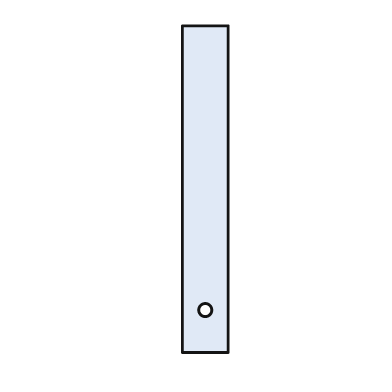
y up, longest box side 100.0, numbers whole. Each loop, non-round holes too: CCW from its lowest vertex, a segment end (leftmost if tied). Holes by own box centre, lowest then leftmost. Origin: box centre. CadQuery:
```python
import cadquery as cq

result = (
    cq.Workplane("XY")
    .moveTo(-7.0, -50.0)
    .lineTo(7.0, -50.0)
    .lineTo(7.0, 50.0)
    .lineTo(-7.0, 50.0)
    .close()
    .moveTo(0.0, -37.0)
    .circle(2.0)
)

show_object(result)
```